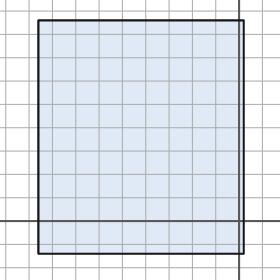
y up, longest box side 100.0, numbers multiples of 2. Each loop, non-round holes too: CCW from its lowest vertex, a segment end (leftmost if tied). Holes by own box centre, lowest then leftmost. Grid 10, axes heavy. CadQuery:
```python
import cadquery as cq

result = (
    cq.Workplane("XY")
    .moveTo(-86.0, -14.0)
    .lineTo(2.0, -14.0)
    .lineTo(2.0, 86.0)
    .lineTo(-86.0, 86.0)
    .close()
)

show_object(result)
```